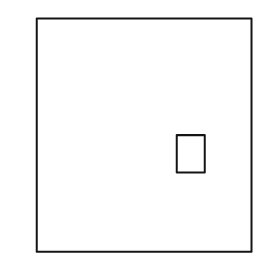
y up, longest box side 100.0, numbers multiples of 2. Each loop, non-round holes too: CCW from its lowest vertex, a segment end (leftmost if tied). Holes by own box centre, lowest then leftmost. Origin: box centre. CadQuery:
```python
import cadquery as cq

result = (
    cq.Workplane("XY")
    .moveTo(-46.0, -50.0)
    .lineTo(46.0, -50.0)
    .lineTo(46.0, 50.0)
    .lineTo(-46.0, 50.0)
    .close()
    .moveTo(14.0, -16.0)
    .lineTo(26.0, -16.0)
    .lineTo(26.0, 0.0)
    .lineTo(14.0, 0.0)
    .close()
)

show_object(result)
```